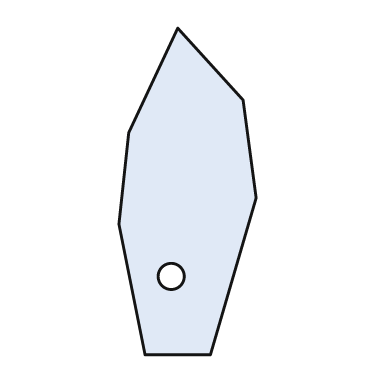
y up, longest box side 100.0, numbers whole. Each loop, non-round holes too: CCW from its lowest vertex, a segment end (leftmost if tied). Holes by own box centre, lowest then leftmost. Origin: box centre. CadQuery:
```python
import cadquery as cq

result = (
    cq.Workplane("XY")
    .moveTo(-13.0, -50.0)
    .lineTo(7.0, -50.0)
    .lineTo(21.0, -2.0)
    .lineTo(17.0, 28.0)
    .lineTo(-3.0, 50.0)
    .lineTo(-18.0, 18.0)
    .lineTo(-21.0, -10.0)
    .close()
    .moveTo(-5.0, -26.0)
    .circle(4.0)
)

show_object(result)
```